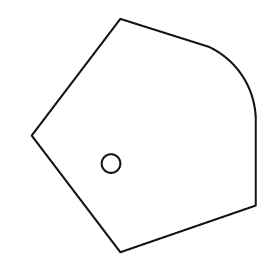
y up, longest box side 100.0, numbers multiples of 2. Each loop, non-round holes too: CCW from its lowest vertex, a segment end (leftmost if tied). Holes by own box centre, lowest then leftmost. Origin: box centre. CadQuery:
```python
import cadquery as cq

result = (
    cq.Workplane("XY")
    .moveTo(-10.0, -50.0)
    .lineTo(48.0, -30.0)
    .lineTo(48.0, 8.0)
    .threePointArc((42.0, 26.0), (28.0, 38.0))
    .lineTo(-10.0, 50.0)
    .lineTo(-48.0, 0.0)
    .close()
    .moveTo(-14.0, -12.0)
    .circle(4.0)
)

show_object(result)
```